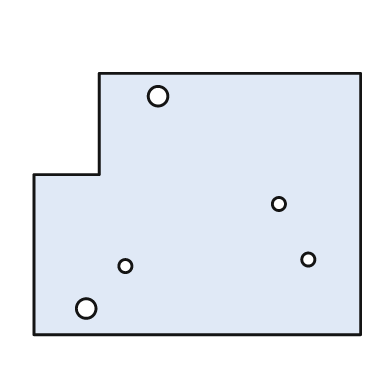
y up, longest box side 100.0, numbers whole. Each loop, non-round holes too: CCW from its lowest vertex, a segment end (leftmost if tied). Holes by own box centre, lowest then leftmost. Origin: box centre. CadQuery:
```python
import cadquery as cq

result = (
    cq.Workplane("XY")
    .moveTo(-50.0, -40.0)
    .lineTo(50.0, -40.0)
    .lineTo(50.0, 40.0)
    .lineTo(-30.0, 40.0)
    .lineTo(-30.0, 9.0)
    .lineTo(-50.0, 9.0)
    .close()
    .moveTo(-34.0, -32.0)
    .circle(3.0)
    .moveTo(-22.0, -19.0)
    .circle(2.0)
    .moveTo(34.0, -17.0)
    .circle(2.0)
    .moveTo(25.0, 0.0)
    .circle(2.0)
    .moveTo(-12.0, 33.0)
    .circle(3.0)
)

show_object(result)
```